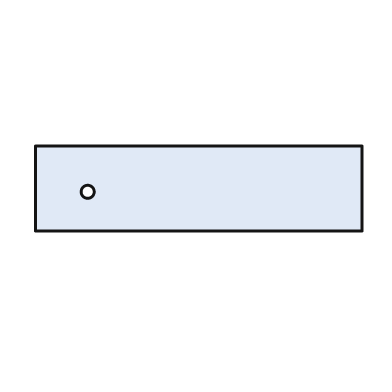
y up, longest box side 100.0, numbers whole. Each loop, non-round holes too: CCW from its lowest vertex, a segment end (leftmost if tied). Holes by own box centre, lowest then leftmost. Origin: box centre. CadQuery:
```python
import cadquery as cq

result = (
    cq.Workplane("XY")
    .moveTo(-50.0, -13.0)
    .lineTo(50.0, -13.0)
    .lineTo(50.0, 13.0)
    .lineTo(-50.0, 13.0)
    .close()
    .moveTo(-34.0, -1.0)
    .circle(2.0)
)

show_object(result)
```